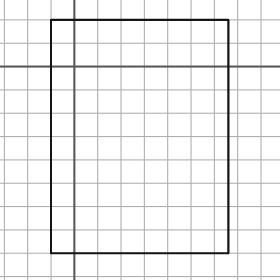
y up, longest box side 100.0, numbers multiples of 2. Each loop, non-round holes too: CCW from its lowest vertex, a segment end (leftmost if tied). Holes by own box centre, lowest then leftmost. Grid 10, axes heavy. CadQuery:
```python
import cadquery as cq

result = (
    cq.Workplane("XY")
    .moveTo(-10.0, -80.0)
    .lineTo(66.0, -80.0)
    .lineTo(66.0, 20.0)
    .lineTo(-10.0, 20.0)
    .close()
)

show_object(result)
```